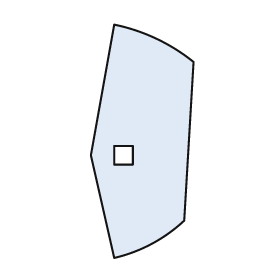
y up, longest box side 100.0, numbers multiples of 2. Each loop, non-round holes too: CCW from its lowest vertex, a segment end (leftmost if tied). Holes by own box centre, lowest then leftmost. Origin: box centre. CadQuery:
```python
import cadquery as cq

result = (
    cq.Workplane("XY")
    .moveTo(-12.0, -50.0)
    .threePointArc((4.0, -44.0), (18.0, -34.0))
    .lineTo(22.0, 34.0)
    .threePointArc((6.0, 44.0), (-12.0, 50.0))
    .lineTo(-22.0, -6.0)
    .close()
    .moveTo(-12.0, -10.0)
    .lineTo(-4.0, -10.0)
    .lineTo(-4.0, -2.0)
    .lineTo(-12.0, -2.0)
    .close()
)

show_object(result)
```